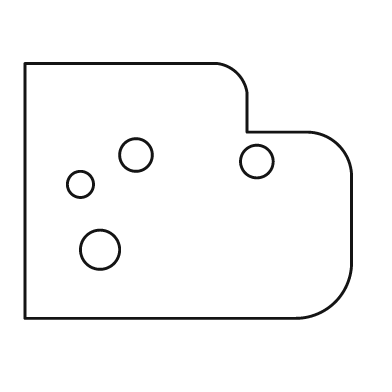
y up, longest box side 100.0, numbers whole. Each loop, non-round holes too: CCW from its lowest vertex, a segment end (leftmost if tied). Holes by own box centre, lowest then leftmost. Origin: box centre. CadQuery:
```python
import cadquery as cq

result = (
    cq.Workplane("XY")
    .moveTo(-50.0, -39.0)
    .lineTo(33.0, -39.0)
    .threePointArc((45.0, -34.0), (50.0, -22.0))
    .lineTo(50.0, 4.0)
    .threePointArc((46.0, 14.0), (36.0, 18.0))
    .lineTo(18.0, 18.0)
    .lineTo(18.0, 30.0)
    .threePointArc((15.0, 36.0), (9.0, 39.0))
    .lineTo(-50.0, 39.0)
    .close()
    .moveTo(-27.0, -18.0)
    .circle(6.0)
    .moveTo(-33.0, 2.0)
    .circle(4.0)
    .moveTo(21.0, 9.0)
    .circle(5.0)
    .moveTo(-16.0, 11.0)
    .circle(5.0)
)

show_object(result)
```